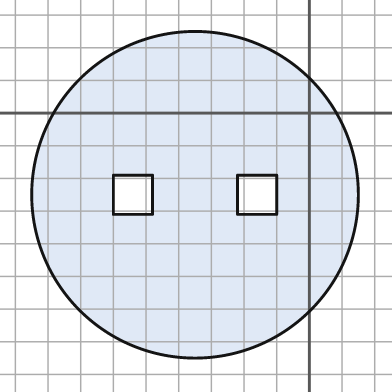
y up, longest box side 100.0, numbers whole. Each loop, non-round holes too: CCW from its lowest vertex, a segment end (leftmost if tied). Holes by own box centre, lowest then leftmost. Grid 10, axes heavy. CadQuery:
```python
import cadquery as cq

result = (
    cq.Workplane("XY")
    .moveTo(-35.0, -25.0)
    .circle(50.0)
    .moveTo(-60.0, -31.0)
    .lineTo(-48.0, -31.0)
    .lineTo(-48.0, -19.0)
    .lineTo(-60.0, -19.0)
    .close()
    .moveTo(-22.0, -31.0)
    .lineTo(-10.0, -31.0)
    .lineTo(-10.0, -19.0)
    .lineTo(-22.0, -19.0)
    .close()
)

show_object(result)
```